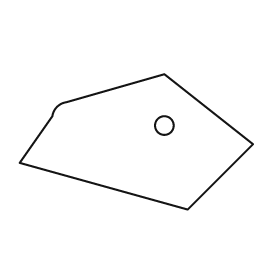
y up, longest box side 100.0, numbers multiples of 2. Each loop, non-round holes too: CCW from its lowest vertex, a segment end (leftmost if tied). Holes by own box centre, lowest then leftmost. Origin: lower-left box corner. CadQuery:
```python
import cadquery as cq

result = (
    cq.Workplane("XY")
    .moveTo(72.0, 0.0)
    .lineTo(100.0, 28.0)
    .lineTo(62.0, 58.0)
    .lineTo(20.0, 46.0)
    .threePointArc((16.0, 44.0), (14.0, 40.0))
    .lineTo(0.0, 20.0)
    .close()
    .moveTo(62.0, 36.0)
    .circle(4.0)
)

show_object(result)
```